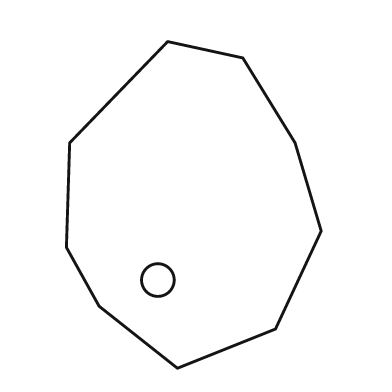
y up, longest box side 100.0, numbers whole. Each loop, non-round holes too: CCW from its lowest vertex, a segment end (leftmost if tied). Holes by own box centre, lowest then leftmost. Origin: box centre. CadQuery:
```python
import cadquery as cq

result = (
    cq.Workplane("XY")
    .moveTo(-5.0, -50.0)
    .lineTo(25.0, -38.0)
    .lineTo(39.0, -8.0)
    .lineTo(31.0, 19.0)
    .lineTo(15.0, 45.0)
    .lineTo(-8.0, 50.0)
    .lineTo(-38.0, 19.0)
    .lineTo(-39.0, -13.0)
    .lineTo(-29.0, -31.0)
    .close()
    .moveTo(-11.0, -23.0)
    .circle(5.0)
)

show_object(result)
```